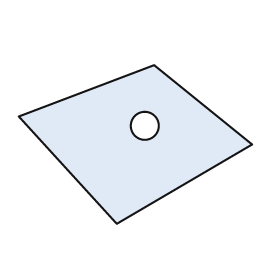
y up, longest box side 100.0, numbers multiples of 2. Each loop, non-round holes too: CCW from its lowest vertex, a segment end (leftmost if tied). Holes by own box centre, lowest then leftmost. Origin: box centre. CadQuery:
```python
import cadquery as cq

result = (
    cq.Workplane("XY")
    .moveTo(-8.0, -34.0)
    .lineTo(50.0, 0.0)
    .lineTo(8.0, 34.0)
    .lineTo(-50.0, 12.0)
    .close()
    .moveTo(4.0, 8.0)
    .circle(6.0)
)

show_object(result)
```